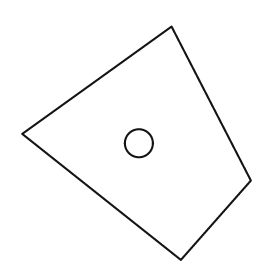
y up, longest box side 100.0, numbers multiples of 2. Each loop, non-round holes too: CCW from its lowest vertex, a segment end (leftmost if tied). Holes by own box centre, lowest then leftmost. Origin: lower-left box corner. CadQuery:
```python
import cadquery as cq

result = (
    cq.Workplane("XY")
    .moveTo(68.0, 0.0)
    .lineTo(98.0, 34.0)
    .lineTo(64.0, 100.0)
    .lineTo(0.0, 54.0)
    .close()
    .moveTo(50.0, 50.0)
    .circle(6.0)
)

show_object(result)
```